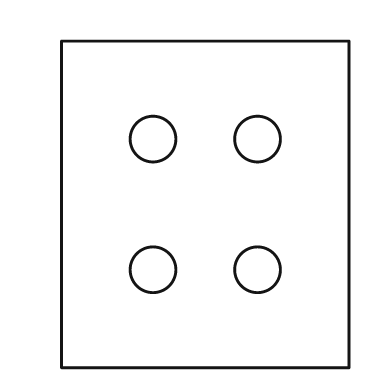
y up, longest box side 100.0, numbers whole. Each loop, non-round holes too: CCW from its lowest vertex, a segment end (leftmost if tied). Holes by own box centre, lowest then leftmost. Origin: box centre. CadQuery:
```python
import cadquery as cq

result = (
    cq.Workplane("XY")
    .moveTo(-44.0, -50.0)
    .lineTo(44.0, -50.0)
    .lineTo(44.0, 50.0)
    .lineTo(-44.0, 50.0)
    .close()
    .moveTo(-16.0, -20.0)
    .circle(7.0)
    .moveTo(16.0, -20.0)
    .circle(7.0)
    .moveTo(-16.0, 20.0)
    .circle(7.0)
    .moveTo(16.0, 20.0)
    .circle(7.0)
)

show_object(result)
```